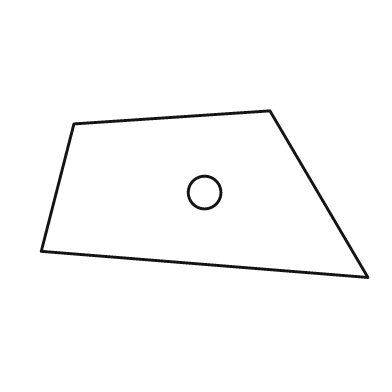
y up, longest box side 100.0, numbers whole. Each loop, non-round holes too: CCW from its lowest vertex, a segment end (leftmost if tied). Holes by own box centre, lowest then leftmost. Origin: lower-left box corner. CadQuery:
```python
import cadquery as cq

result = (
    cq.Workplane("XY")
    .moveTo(100.0, 0.0)
    .lineTo(70.0, 51.0)
    .lineTo(10.0, 47.0)
    .lineTo(0.0, 8.0)
    .close()
    .moveTo(50.0, 26.0)
    .circle(5.0)
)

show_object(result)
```